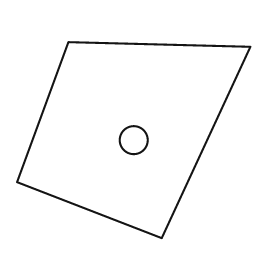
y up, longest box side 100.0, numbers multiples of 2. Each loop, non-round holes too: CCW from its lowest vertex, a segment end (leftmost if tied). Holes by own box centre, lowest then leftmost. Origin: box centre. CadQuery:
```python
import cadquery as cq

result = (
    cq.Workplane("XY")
    .moveTo(12.0, -42.0)
    .lineTo(50.0, 40.0)
    .lineTo(-28.0, 42.0)
    .lineTo(-50.0, -18.0)
    .close()
    .moveTo(0.0, 0.0)
    .circle(6.0)
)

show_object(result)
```